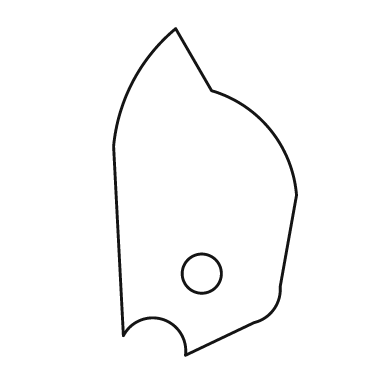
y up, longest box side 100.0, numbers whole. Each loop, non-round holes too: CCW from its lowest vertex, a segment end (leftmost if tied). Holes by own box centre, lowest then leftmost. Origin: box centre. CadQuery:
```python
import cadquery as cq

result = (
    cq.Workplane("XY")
    .moveTo(-6.0, -50.0)
    .lineTo(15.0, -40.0)
    .threePointArc((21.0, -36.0), (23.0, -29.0))
    .lineTo(28.0, -1.0)
    .threePointArc((20.0, 19.0), (2.0, 31.0))
    .lineTo(-9.0, 50.0)
    .threePointArc((-22.0, 34.0), (-28.0, 14.0))
    .lineTo(-25.0, -44.0)
    .threePointArc((-13.0, -39.0), (-6.0, -50.0))
    .close()
    .moveTo(-1.0, -25.0)
    .circle(6.0)
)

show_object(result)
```